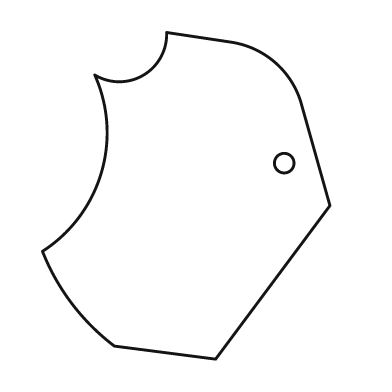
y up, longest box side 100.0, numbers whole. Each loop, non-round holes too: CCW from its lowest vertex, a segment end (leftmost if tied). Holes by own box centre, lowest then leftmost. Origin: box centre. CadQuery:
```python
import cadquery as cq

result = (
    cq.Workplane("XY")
    .moveTo(9.0, -50.0)
    .lineTo(44.0, -3.0)
    .lineTo(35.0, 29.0)
    .threePointArc((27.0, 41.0), (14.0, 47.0))
    .lineTo(-6.0, 50.0)
    .threePointArc((-13.0, 37.0), (-28.0, 37.0))
    .threePointArc((-26.0, 7.0), (-44.0, -17.0))
    .threePointArc((-35.0, -33.0), (-22.0, -46.0))
    .close()
    .moveTo(30.0, 10.0)
    .circle(3.0)
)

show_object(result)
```